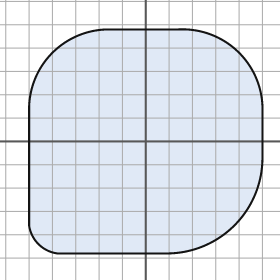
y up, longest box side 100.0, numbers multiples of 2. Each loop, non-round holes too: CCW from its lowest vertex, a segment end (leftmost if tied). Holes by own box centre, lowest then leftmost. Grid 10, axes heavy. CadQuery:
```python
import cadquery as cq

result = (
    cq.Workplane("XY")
    .moveTo(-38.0, -48.0)
    .lineTo(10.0, -48.0)
    .threePointArc((38.0, -36.0), (50.0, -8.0))
    .lineTo(50.0, 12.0)
    .threePointArc((40.0, 38.0), (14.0, 48.0))
    .lineTo(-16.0, 48.0)
    .threePointArc((-40.0, 38.0), (-50.0, 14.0))
    .lineTo(-50.0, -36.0)
    .threePointArc((-46.0, -44.0), (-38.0, -48.0))
    .close()
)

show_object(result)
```